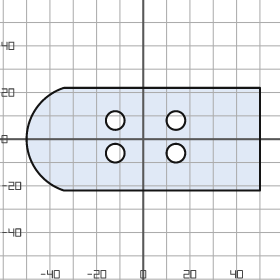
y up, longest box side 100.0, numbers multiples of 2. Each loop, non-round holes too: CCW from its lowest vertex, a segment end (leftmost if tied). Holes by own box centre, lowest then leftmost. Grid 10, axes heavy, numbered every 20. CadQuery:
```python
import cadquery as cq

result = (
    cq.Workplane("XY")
    .moveTo(-34.0, -22.0)
    .lineTo(50.0, -22.0)
    .lineTo(50.0, 22.0)
    .lineTo(-34.0, 22.0)
    .threePointArc((-50.0, 0.0), (-34.0, -22.0))
    .close()
    .moveTo(-12.0, -6.0)
    .circle(4.0)
    .moveTo(14.0, -6.0)
    .circle(4.0)
    .moveTo(-12.0, 8.0)
    .circle(4.0)
    .moveTo(14.0, 8.0)
    .circle(4.0)
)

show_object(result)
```